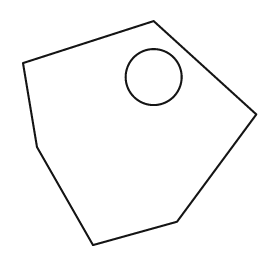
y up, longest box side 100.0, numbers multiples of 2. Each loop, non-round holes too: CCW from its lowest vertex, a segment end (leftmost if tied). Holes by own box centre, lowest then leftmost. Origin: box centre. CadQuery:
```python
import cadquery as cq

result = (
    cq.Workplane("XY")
    .moveTo(-20.0, -48.0)
    .lineTo(16.0, -38.0)
    .lineTo(50.0, 8.0)
    .lineTo(6.0, 48.0)
    .lineTo(-50.0, 30.0)
    .lineTo(-44.0, -6.0)
    .close()
    .moveTo(6.0, 24.0)
    .circle(12.0)
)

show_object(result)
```